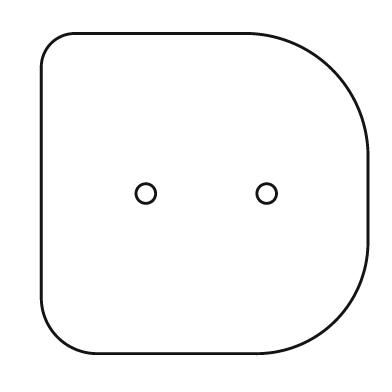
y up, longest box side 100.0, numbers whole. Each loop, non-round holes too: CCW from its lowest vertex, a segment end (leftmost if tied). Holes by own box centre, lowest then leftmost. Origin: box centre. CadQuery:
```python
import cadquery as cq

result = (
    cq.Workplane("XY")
    .moveTo(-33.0, -49.0)
    .lineTo(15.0, -49.0)
    .threePointArc((40.0, -39.0), (50.0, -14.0))
    .lineTo(50.0, 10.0)
    .threePointArc((39.0, 38.0), (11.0, 49.0))
    .lineTo(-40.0, 49.0)
    .threePointArc((-47.0, 46.0), (-50.0, 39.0))
    .lineTo(-50.0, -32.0)
    .threePointArc((-45.0, -44.0), (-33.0, -49.0))
    .close()
    .moveTo(-18.0, 0.0)
    .circle(3.0)
    .moveTo(19.0, 0.0)
    .circle(3.0)
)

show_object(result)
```